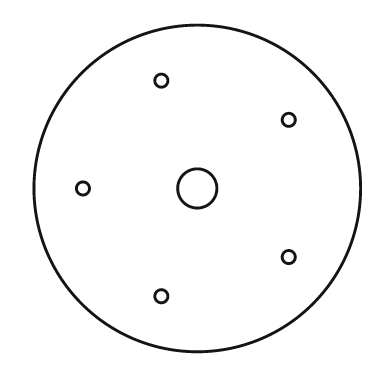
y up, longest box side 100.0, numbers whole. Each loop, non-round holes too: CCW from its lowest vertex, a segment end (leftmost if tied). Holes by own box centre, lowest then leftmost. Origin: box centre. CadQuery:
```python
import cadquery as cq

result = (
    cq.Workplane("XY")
    .moveTo(0.0, 0.0)
    .circle(50.0)
    .moveTo(-11.0, -33.0)
    .circle(2.0)
    .moveTo(28.0, -21.0)
    .circle(2.0)
    .moveTo(-35.0, 0.0)
    .circle(2.0)
    .moveTo(0.0, 0.0)
    .circle(6.0)
    .moveTo(28.0, 21.0)
    .circle(2.0)
    .moveTo(-11.0, 33.0)
    .circle(2.0)
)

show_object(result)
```